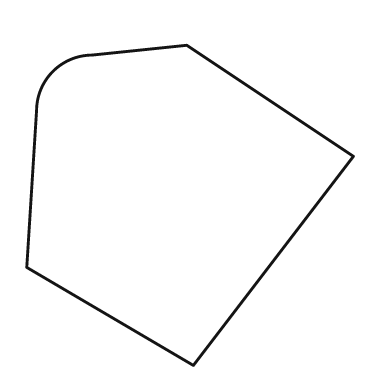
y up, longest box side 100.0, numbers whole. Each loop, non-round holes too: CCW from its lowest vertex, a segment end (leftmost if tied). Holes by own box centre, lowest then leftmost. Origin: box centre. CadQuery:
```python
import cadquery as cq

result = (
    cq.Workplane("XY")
    .moveTo(1.0, -49.0)
    .lineTo(50.0, 15.0)
    .lineTo(-1.0, 49.0)
    .lineTo(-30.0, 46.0)
    .threePointArc((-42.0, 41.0), (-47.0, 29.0))
    .lineTo(-50.0, -19.0)
    .close()
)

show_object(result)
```